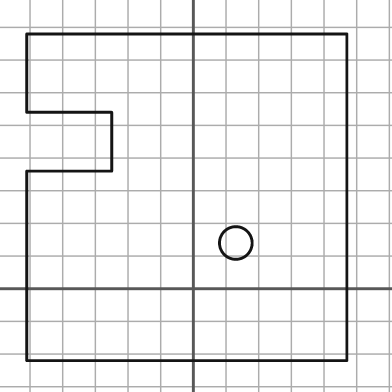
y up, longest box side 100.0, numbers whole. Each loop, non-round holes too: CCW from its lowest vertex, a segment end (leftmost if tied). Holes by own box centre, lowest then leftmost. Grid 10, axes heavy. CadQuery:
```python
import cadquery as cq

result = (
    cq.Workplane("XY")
    .moveTo(-51.0, -22.0)
    .lineTo(47.0, -22.0)
    .lineTo(47.0, 78.0)
    .lineTo(-51.0, 78.0)
    .lineTo(-51.0, 54.0)
    .lineTo(-25.0, 54.0)
    .lineTo(-25.0, 36.0)
    .lineTo(-51.0, 36.0)
    .close()
    .moveTo(13.0, 14.0)
    .circle(5.0)
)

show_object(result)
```